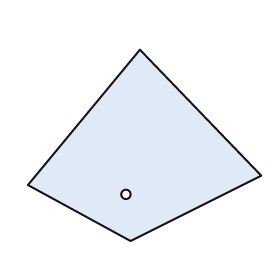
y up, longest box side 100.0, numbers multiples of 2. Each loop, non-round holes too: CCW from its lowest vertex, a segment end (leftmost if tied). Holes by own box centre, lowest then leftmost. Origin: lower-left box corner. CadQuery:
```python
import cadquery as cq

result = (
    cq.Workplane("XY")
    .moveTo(44.0, 0.0)
    .lineTo(100.0, 28.0)
    .lineTo(48.0, 82.0)
    .lineTo(0.0, 24.0)
    .close()
    .moveTo(42.0, 20.0)
    .circle(2.0)
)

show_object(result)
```